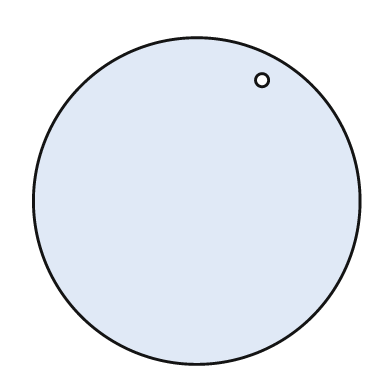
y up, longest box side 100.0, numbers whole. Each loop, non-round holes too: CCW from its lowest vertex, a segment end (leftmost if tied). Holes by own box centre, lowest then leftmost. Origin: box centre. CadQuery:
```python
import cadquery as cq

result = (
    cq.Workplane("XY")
    .moveTo(0.0, 0.0)
    .circle(50.0)
    .moveTo(20.0, 37.0)
    .circle(2.0)
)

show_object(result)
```